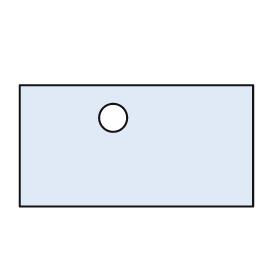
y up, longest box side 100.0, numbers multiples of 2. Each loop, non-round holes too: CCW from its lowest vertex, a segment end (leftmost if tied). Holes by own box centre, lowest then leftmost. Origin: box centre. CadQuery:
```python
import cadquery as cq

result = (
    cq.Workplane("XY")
    .moveTo(-50.0, -26.0)
    .lineTo(50.0, -26.0)
    .lineTo(50.0, 26.0)
    .lineTo(-50.0, 26.0)
    .close()
    .moveTo(-10.0, 12.0)
    .circle(6.0)
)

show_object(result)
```